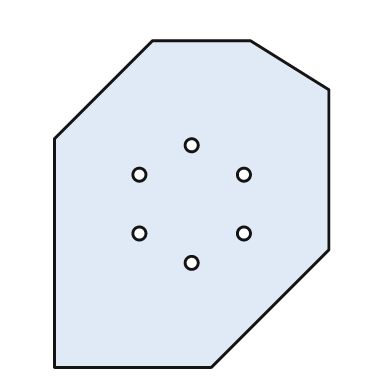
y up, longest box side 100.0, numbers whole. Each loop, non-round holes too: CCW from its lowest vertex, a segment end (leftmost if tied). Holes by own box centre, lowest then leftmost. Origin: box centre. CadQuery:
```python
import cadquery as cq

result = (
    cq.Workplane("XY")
    .moveTo(-42.0, -50.0)
    .lineTo(6.0, -50.0)
    .lineTo(42.0, -14.0)
    .lineTo(42.0, 35.0)
    .lineTo(18.0, 50.0)
    .lineTo(-12.0, 50.0)
    .lineTo(-42.0, 20.0)
    .close()
    .moveTo(0.0, -18.0)
    .circle(2.0)
    .moveTo(-16.0, -9.0)
    .circle(2.0)
    .moveTo(16.0, -9.0)
    .circle(2.0)
    .moveTo(-16.0, 9.0)
    .circle(2.0)
    .moveTo(16.0, 9.0)
    .circle(2.0)
    .moveTo(0.0, 18.0)
    .circle(2.0)
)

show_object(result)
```